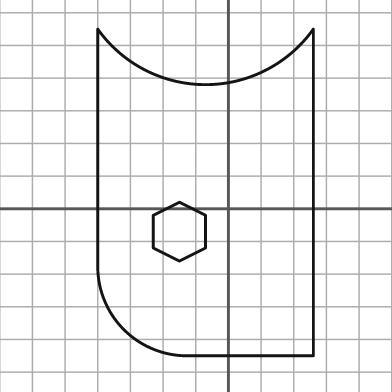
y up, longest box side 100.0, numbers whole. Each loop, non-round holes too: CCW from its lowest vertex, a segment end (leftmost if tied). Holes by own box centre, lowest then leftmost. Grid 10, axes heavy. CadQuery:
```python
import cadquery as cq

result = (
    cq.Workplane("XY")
    .moveTo(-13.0, -45.0)
    .lineTo(26.0, -45.0)
    .lineTo(26.0, 55.0)
    .threePointArc((-7.0, 38.0), (-40.0, 55.0))
    .lineTo(-40.0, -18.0)
    .threePointArc((-32.0, -37.0), (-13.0, -45.0))
    .close()
    .moveTo(-15.0, -16.0)
    .lineTo(-7.0, -12.0)
    .lineTo(-7.0, -2.0)
    .lineTo(-15.0, 2.0)
    .lineTo(-23.0, -2.0)
    .lineTo(-23.0, -12.0)
    .close()
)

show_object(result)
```